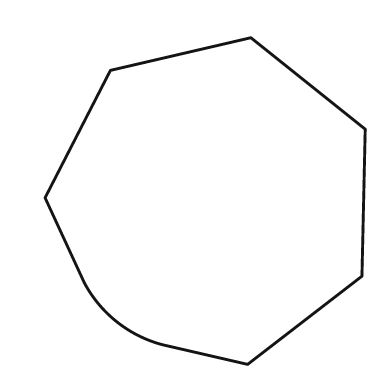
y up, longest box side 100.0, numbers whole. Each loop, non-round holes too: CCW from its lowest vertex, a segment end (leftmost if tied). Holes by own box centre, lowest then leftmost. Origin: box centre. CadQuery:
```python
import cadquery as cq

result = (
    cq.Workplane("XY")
    .moveTo(13.0, -50.0)
    .lineTo(48.0, -23.0)
    .lineTo(49.0, 22.0)
    .lineTo(14.0, 50.0)
    .lineTo(-29.0, 40.0)
    .lineTo(-49.0, 1.0)
    .lineTo(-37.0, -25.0)
    .threePointArc((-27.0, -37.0), (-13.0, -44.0))
    .close()
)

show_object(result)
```